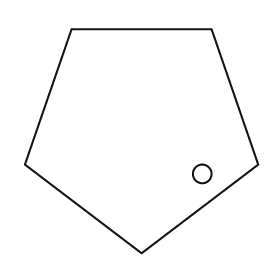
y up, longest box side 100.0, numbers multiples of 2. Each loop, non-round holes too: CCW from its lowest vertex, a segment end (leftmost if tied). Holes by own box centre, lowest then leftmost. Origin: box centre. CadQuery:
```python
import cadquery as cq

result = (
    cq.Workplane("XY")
    .moveTo(0.0, -48.0)
    .lineTo(50.0, -10.0)
    .lineTo(30.0, 48.0)
    .lineTo(-30.0, 48.0)
    .lineTo(-50.0, -10.0)
    .close()
    .moveTo(26.0, -14.0)
    .circle(4.0)
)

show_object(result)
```